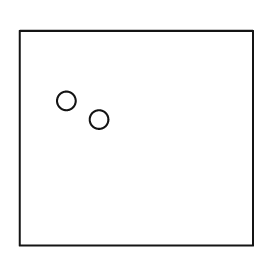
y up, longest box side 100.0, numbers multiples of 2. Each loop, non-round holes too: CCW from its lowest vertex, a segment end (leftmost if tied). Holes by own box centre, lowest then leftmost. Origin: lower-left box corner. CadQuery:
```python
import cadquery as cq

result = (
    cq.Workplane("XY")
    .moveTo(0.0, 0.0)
    .lineTo(100.0, 0.0)
    .lineTo(100.0, 92.0)
    .lineTo(0.0, 92.0)
    .close()
    .moveTo(34.0, 54.0)
    .circle(4.0)
    .moveTo(20.0, 62.0)
    .circle(4.0)
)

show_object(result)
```